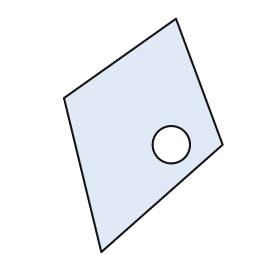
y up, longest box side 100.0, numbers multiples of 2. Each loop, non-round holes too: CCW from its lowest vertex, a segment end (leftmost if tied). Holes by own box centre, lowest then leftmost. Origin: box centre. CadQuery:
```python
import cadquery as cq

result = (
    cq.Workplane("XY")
    .moveTo(-18.0, -50.0)
    .lineTo(34.0, -4.0)
    .lineTo(14.0, 50.0)
    .lineTo(-34.0, 16.0)
    .close()
    .moveTo(12.0, -4.0)
    .circle(8.0)
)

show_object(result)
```